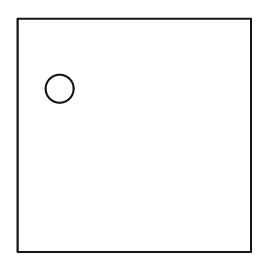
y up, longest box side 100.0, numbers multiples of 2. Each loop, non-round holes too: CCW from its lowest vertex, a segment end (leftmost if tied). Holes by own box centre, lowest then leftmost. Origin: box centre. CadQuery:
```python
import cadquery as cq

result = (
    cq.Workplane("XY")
    .moveTo(-50.0, -50.0)
    .lineTo(50.0, -50.0)
    .lineTo(50.0, 50.0)
    .lineTo(-50.0, 50.0)
    .close()
    .moveTo(-32.0, 20.0)
    .circle(6.0)
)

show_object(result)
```